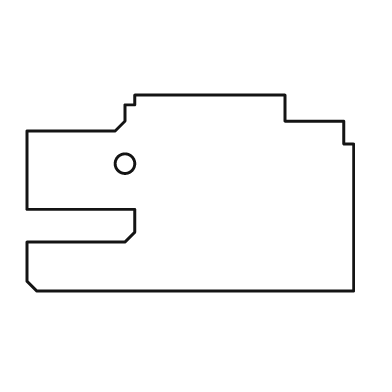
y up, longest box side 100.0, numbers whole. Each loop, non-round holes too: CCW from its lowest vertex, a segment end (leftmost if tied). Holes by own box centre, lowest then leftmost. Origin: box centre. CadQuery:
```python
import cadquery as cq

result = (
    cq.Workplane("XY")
    .moveTo(-47.0, -30.0)
    .lineTo(50.0, -30.0)
    .lineTo(50.0, 15.0)
    .lineTo(47.0, 15.0)
    .lineTo(47.0, 22.0)
    .lineTo(29.0, 22.0)
    .lineTo(29.0, 30.0)
    .lineTo(-17.0, 30.0)
    .lineTo(-17.0, 27.0)
    .lineTo(-20.0, 27.0)
    .lineTo(-20.0, 22.0)
    .lineTo(-23.0, 19.0)
    .lineTo(-50.0, 19.0)
    .lineTo(-50.0, -5.0)
    .lineTo(-17.0, -5.0)
    .lineTo(-17.0, -12.0)
    .lineTo(-20.0, -15.0)
    .lineTo(-50.0, -15.0)
    .lineTo(-50.0, -27.0)
    .close()
    .moveTo(-20.0, 9.0)
    .circle(3.0)
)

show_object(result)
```